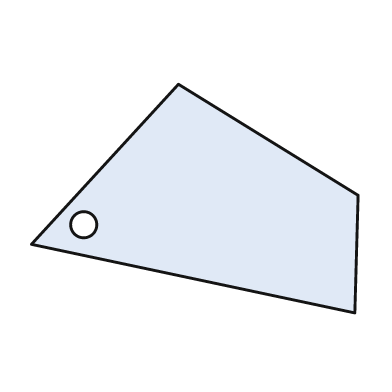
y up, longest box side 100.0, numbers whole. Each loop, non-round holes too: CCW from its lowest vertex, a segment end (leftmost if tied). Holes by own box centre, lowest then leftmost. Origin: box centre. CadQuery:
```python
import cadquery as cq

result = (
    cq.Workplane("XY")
    .moveTo(49.0, -35.0)
    .lineTo(50.0, 1.0)
    .lineTo(-5.0, 35.0)
    .lineTo(-50.0, -14.0)
    .close()
    .moveTo(-34.0, -8.0)
    .circle(4.0)
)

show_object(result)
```